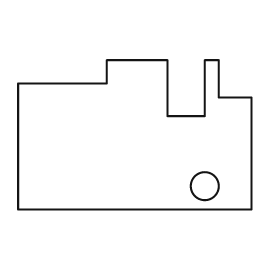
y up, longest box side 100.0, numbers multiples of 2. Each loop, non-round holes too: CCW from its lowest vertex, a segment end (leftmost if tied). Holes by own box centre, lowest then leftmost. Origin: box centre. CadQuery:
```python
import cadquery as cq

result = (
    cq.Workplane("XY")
    .moveTo(-50.0, -32.0)
    .lineTo(50.0, -32.0)
    .lineTo(50.0, 16.0)
    .lineTo(36.0, 16.0)
    .lineTo(36.0, 32.0)
    .lineTo(30.0, 32.0)
    .lineTo(30.0, 8.0)
    .lineTo(14.0, 8.0)
    .lineTo(14.0, 32.0)
    .lineTo(-12.0, 32.0)
    .lineTo(-12.0, 22.0)
    .lineTo(-50.0, 22.0)
    .close()
    .moveTo(30.0, -22.0)
    .circle(6.0)
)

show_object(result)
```